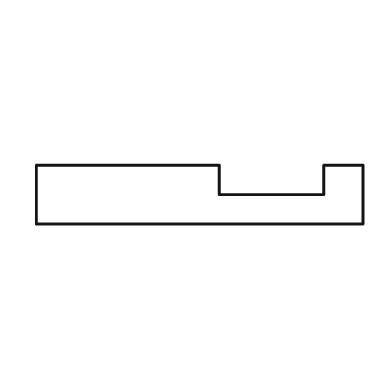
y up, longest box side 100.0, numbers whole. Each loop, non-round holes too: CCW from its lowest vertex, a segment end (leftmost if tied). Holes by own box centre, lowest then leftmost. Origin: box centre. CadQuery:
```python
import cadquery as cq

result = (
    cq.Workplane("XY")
    .moveTo(-50.0, -9.0)
    .lineTo(50.0, -9.0)
    .lineTo(50.0, 9.0)
    .lineTo(38.0, 9.0)
    .lineTo(38.0, 0.0)
    .lineTo(6.0, 0.0)
    .lineTo(6.0, 9.0)
    .lineTo(-50.0, 9.0)
    .close()
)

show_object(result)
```